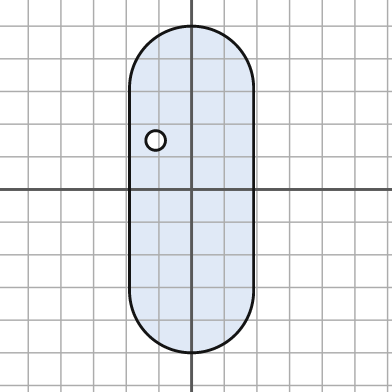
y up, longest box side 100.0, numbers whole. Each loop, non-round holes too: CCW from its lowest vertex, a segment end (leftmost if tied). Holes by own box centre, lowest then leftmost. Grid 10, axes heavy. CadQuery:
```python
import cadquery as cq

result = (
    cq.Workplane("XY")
    .moveTo(-19.0, -31.0)
    .threePointArc((0.0, -50.0), (19.0, -31.0))
    .lineTo(19.0, 31.0)
    .threePointArc((0.0, 50.0), (-19.0, 31.0))
    .close()
    .moveTo(-11.0, 15.0)
    .circle(3.0)
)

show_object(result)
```